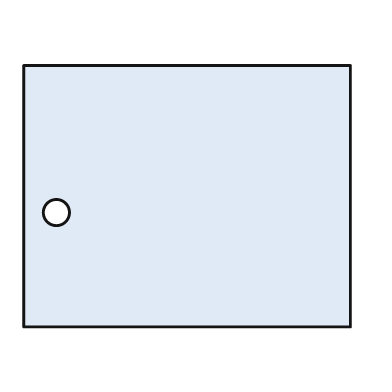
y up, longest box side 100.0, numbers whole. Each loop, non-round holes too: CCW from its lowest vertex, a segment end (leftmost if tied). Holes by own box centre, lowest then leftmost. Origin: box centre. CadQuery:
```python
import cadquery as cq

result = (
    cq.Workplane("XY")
    .moveTo(-50.0, -40.0)
    .lineTo(50.0, -40.0)
    .lineTo(50.0, 40.0)
    .lineTo(-50.0, 40.0)
    .close()
    .moveTo(-40.0, -5.0)
    .circle(4.0)
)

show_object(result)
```